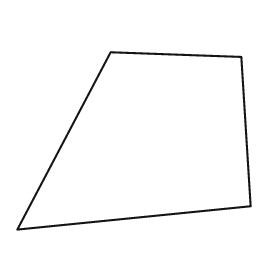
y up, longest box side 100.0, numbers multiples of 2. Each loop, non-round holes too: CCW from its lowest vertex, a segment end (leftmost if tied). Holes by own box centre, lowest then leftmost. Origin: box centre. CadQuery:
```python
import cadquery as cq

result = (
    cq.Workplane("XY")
    .moveTo(-50.0, -38.0)
    .lineTo(50.0, -28.0)
    .lineTo(46.0, 36.0)
    .lineTo(-10.0, 38.0)
    .close()
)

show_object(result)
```